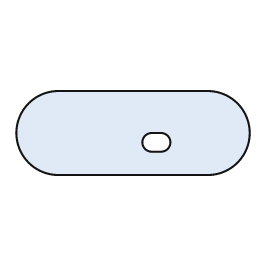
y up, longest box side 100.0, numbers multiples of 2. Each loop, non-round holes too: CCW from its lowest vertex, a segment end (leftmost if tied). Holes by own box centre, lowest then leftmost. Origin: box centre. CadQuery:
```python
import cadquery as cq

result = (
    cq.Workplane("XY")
    .moveTo(-32.0, -18.0)
    .lineTo(32.0, -18.0)
    .threePointArc((50.0, 0.0), (32.0, 18.0))
    .lineTo(-32.0, 18.0)
    .threePointArc((-50.0, 0.0), (-32.0, -18.0))
    .close()
    .moveTo(8.0, -8.0)
    .lineTo(12.0, -8.0)
    .threePointArc((16.0, -4.0), (12.0, 0.0))
    .lineTo(8.0, 0.0)
    .threePointArc((4.0, -4.0), (8.0, -8.0))
    .close()
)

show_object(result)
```